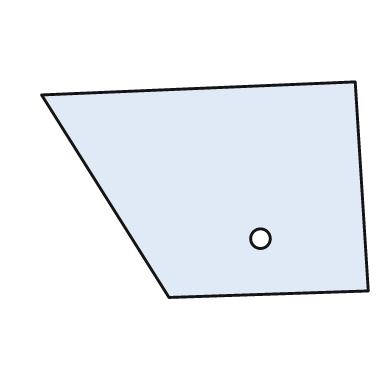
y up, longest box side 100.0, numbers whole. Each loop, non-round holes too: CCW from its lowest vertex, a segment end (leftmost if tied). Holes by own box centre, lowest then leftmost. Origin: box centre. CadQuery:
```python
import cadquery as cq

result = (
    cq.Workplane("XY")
    .moveTo(-11.0, -33.0)
    .lineTo(50.0, -31.0)
    .lineTo(46.0, 33.0)
    .lineTo(-50.0, 29.0)
    .close()
    .moveTo(17.0, -15.0)
    .circle(3.0)
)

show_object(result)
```